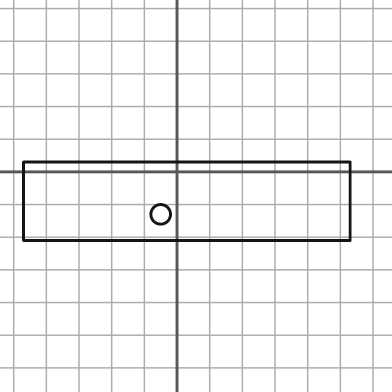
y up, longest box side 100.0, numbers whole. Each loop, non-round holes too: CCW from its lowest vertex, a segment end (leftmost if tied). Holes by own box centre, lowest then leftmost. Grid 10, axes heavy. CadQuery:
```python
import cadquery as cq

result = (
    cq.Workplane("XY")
    .moveTo(-47.0, -21.0)
    .lineTo(53.0, -21.0)
    .lineTo(53.0, 3.0)
    .lineTo(-47.0, 3.0)
    .close()
    .moveTo(-5.0, -13.0)
    .circle(3.0)
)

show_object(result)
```